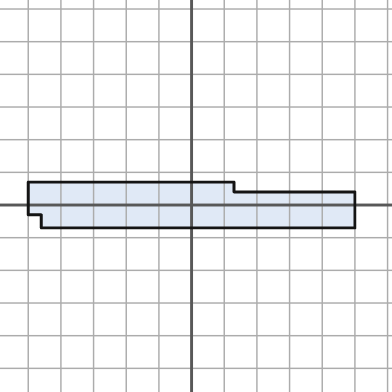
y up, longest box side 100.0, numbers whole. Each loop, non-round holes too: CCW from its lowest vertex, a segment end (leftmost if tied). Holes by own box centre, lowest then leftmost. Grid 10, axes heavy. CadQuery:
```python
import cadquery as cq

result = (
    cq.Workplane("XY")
    .moveTo(-46.0, -7.0)
    .lineTo(50.0, -7.0)
    .lineTo(50.0, 4.0)
    .lineTo(13.0, 4.0)
    .lineTo(13.0, 7.0)
    .lineTo(-50.0, 7.0)
    .lineTo(-50.0, -3.0)
    .lineTo(-46.0, -3.0)
    .close()
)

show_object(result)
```